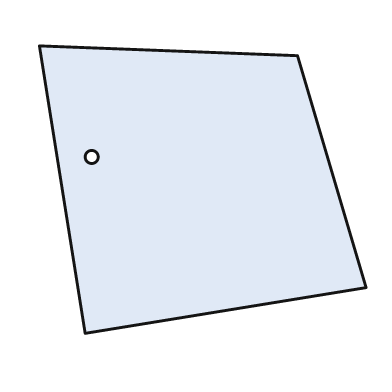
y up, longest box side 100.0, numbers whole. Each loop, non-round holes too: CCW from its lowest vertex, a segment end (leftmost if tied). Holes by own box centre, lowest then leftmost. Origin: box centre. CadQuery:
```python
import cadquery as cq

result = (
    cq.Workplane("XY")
    .moveTo(-36.0, -44.0)
    .lineTo(50.0, -30.0)
    .lineTo(29.0, 41.0)
    .lineTo(-50.0, 44.0)
    .close()
    .moveTo(-34.0, 10.0)
    .circle(2.0)
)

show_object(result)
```